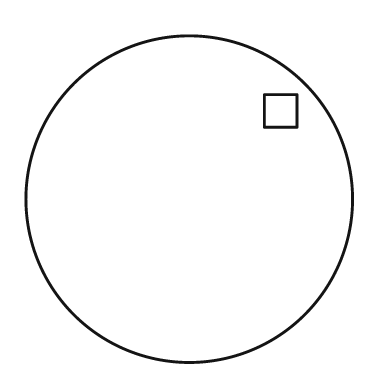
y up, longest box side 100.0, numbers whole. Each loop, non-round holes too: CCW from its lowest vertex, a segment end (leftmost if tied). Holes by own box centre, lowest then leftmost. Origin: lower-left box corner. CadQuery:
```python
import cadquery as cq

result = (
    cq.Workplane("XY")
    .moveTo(50.0, 50.0)
    .circle(50.0)
    .moveTo(73.0, 72.0)
    .lineTo(83.0, 72.0)
    .lineTo(83.0, 82.0)
    .lineTo(73.0, 82.0)
    .close()
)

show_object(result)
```